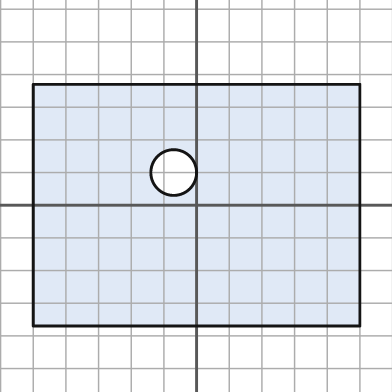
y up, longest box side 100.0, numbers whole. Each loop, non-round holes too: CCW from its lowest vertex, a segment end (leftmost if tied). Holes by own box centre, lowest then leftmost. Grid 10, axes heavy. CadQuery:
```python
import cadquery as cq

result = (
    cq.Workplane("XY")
    .moveTo(-50.0, -37.0)
    .lineTo(50.0, -37.0)
    .lineTo(50.0, 37.0)
    .lineTo(-50.0, 37.0)
    .close()
    .moveTo(-7.0, 10.0)
    .circle(7.0)
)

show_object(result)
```